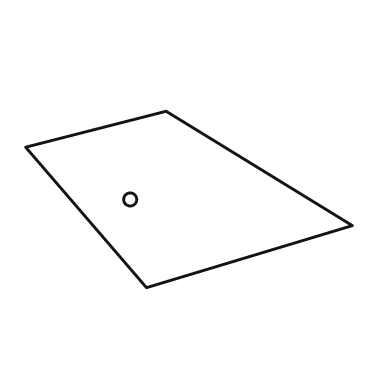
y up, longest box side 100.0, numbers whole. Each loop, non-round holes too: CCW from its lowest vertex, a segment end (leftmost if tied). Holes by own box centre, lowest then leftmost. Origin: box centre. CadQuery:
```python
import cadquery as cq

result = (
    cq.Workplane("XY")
    .moveTo(-13.0, -27.0)
    .lineTo(50.0, -8.0)
    .lineTo(-7.0, 27.0)
    .lineTo(-50.0, 16.0)
    .close()
    .moveTo(-18.0, 0.0)
    .circle(2.0)
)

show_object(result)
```